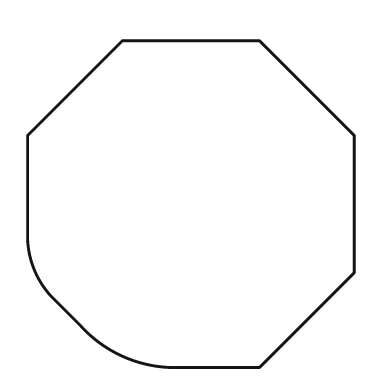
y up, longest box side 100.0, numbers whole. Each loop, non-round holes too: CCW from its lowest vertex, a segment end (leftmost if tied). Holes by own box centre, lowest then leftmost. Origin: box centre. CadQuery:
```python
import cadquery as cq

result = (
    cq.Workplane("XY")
    .moveTo(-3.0, -50.0)
    .lineTo(21.0, -50.0)
    .lineTo(50.0, -21.0)
    .lineTo(50.0, 21.0)
    .lineTo(21.0, 50.0)
    .lineTo(-21.0, 50.0)
    .lineTo(-50.0, 21.0)
    .lineTo(-50.0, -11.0)
    .threePointArc((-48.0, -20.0), (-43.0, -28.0))
    .lineTo(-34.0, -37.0)
    .threePointArc((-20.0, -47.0), (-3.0, -50.0))
    .close()
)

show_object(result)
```